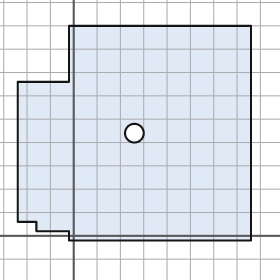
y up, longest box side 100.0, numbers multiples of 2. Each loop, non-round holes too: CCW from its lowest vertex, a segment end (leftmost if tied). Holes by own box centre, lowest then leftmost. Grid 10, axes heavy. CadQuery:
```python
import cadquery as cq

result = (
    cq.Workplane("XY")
    .moveTo(-2.0, -2.0)
    .lineTo(76.0, -2.0)
    .lineTo(76.0, 90.0)
    .lineTo(-2.0, 90.0)
    .lineTo(-2.0, 66.0)
    .lineTo(-24.0, 66.0)
    .lineTo(-24.0, 6.0)
    .lineTo(-16.0, 6.0)
    .lineTo(-16.0, 2.0)
    .lineTo(-2.0, 2.0)
    .close()
    .moveTo(26.0, 44.0)
    .circle(4.0)
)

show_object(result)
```